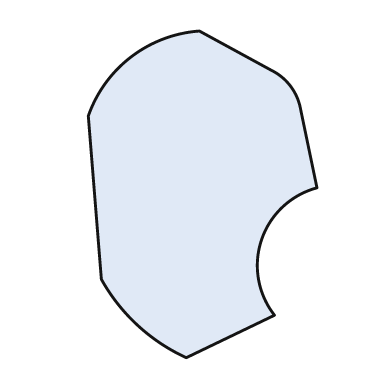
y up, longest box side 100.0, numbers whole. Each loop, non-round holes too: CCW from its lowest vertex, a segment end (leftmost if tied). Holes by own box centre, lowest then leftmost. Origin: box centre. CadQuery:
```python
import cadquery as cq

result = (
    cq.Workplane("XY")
    .moveTo(-5.0, -50.0)
    .lineTo(22.0, -37.0)
    .threePointArc((18.0, -14.0), (35.0, 2.0))
    .lineTo(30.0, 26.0)
    .threePointArc((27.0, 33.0), (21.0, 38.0))
    .lineTo(-1.0, 50.0)
    .threePointArc((-22.0, 42.0), (-35.0, 24.0))
    .lineTo(-31.0, -26.0)
    .threePointArc((-20.0, -40.0), (-5.0, -50.0))
    .close()
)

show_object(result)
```